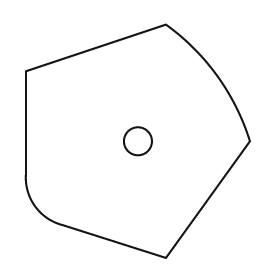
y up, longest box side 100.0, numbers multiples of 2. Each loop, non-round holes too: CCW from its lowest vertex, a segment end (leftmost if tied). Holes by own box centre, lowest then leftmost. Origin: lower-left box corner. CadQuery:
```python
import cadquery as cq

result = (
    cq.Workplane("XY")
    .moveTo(60.0, 0.0)
    .lineTo(96.0, 50.0)
    .threePointArc((82.0, 78.0), (60.0, 100.0))
    .lineTo(0.0, 80.0)
    .lineTo(0.0, 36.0)
    .threePointArc((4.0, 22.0), (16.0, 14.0))
    .close()
    .moveTo(48.0, 50.0)
    .circle(6.0)
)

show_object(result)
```